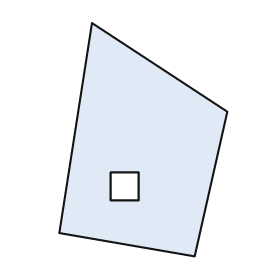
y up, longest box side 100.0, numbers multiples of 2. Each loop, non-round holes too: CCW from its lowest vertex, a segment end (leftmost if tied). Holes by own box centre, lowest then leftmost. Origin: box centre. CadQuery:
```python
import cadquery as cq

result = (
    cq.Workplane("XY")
    .moveTo(22.0, -50.0)
    .lineTo(36.0, 12.0)
    .lineTo(-22.0, 50.0)
    .lineTo(-36.0, -40.0)
    .close()
    .moveTo(-14.0, -26.0)
    .lineTo(-2.0, -26.0)
    .lineTo(-2.0, -14.0)
    .lineTo(-14.0, -14.0)
    .close()
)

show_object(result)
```